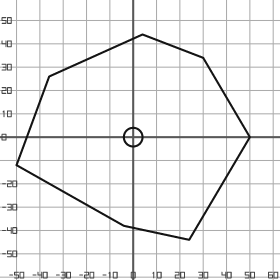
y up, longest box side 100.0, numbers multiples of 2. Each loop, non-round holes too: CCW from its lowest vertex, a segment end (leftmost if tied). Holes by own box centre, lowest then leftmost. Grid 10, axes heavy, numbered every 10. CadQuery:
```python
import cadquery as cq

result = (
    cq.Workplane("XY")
    .moveTo(24.0, -44.0)
    .lineTo(50.0, 0.0)
    .lineTo(30.0, 34.0)
    .lineTo(4.0, 44.0)
    .lineTo(-36.0, 26.0)
    .lineTo(-50.0, -12.0)
    .lineTo(-4.0, -38.0)
    .close()
    .moveTo(0.0, 0.0)
    .circle(4.0)
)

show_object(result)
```